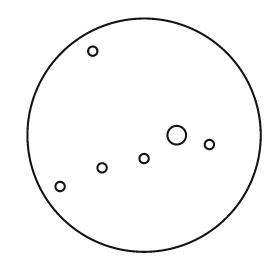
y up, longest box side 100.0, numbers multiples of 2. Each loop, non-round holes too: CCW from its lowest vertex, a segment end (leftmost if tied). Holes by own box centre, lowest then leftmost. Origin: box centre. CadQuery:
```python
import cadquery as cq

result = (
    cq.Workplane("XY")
    .moveTo(0.0, 0.0)
    .circle(50.0)
    .moveTo(-36.0, -22.0)
    .circle(2.0)
    .moveTo(-18.0, -14.0)
    .circle(2.0)
    .moveTo(0.0, -10.0)
    .circle(2.0)
    .moveTo(28.0, -4.0)
    .circle(2.0)
    .moveTo(14.0, 0.0)
    .circle(4.0)
    .moveTo(-22.0, 36.0)
    .circle(2.0)
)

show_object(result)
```